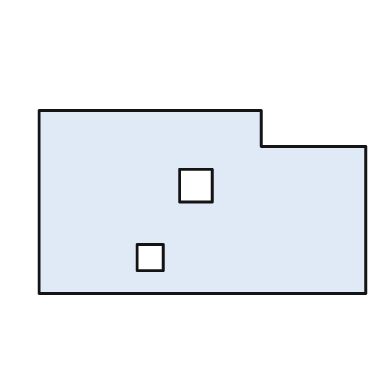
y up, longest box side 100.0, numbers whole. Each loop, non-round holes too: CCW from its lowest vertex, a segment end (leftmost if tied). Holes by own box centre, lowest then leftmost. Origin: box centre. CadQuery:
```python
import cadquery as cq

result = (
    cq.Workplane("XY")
    .moveTo(-50.0, -28.0)
    .lineTo(50.0, -28.0)
    .lineTo(50.0, 17.0)
    .lineTo(18.0, 17.0)
    .lineTo(18.0, 28.0)
    .lineTo(-50.0, 28.0)
    .close()
    .moveTo(-20.0, -21.0)
    .lineTo(-12.0, -21.0)
    .lineTo(-12.0, -13.0)
    .lineTo(-20.0, -13.0)
    .close()
    .moveTo(-7.0, 0.0)
    .lineTo(3.0, 0.0)
    .lineTo(3.0, 10.0)
    .lineTo(-7.0, 10.0)
    .close()
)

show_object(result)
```